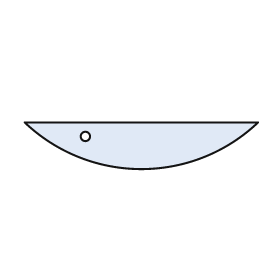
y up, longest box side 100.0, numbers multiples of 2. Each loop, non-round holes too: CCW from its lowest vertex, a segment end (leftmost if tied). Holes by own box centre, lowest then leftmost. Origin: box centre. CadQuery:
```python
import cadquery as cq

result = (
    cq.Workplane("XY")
    .moveTo(-50.0, 10.0)
    .threePointArc((0.0, -10.0), (50.0, 10.0))
    .close()
    .moveTo(-24.0, 4.0)
    .circle(2.0)
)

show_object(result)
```